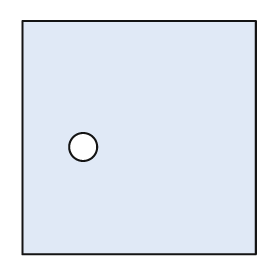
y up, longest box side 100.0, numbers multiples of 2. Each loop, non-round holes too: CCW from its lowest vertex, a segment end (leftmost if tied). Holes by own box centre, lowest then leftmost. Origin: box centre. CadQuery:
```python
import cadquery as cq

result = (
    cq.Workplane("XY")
    .moveTo(-50.0, -50.0)
    .lineTo(50.0, -50.0)
    .lineTo(50.0, 50.0)
    .lineTo(-50.0, 50.0)
    .close()
    .moveTo(-24.0, -4.0)
    .circle(6.0)
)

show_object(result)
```